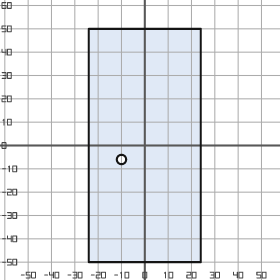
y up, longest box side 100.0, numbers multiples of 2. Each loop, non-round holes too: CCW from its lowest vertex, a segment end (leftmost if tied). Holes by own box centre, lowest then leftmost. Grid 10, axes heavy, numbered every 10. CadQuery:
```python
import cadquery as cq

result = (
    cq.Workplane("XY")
    .moveTo(-24.0, -50.0)
    .lineTo(24.0, -50.0)
    .lineTo(24.0, 50.0)
    .lineTo(-24.0, 50.0)
    .close()
    .moveTo(-10.0, -6.0)
    .circle(2.0)
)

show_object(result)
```